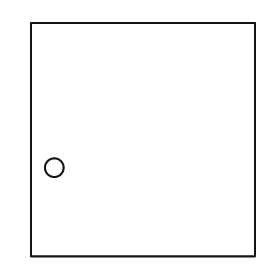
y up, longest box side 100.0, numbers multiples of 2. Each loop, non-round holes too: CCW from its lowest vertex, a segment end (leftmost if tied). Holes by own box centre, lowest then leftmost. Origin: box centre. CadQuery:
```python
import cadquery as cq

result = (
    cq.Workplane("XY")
    .moveTo(-48.0, -50.0)
    .lineTo(48.0, -50.0)
    .lineTo(48.0, 50.0)
    .lineTo(-48.0, 50.0)
    .close()
    .moveTo(-38.0, -12.0)
    .circle(4.0)
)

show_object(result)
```